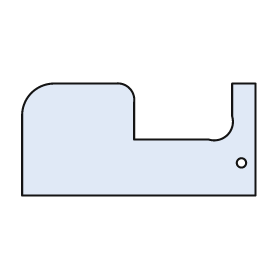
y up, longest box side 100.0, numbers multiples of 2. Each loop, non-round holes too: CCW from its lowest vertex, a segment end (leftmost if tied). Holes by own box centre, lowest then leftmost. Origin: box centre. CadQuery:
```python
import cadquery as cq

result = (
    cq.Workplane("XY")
    .moveTo(-50.0, -24.0)
    .lineTo(50.0, -24.0)
    .lineTo(50.0, 24.0)
    .lineTo(40.0, 24.0)
    .lineTo(40.0, 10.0)
    .threePointArc((38.0, 2.0), (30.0, 0.0))
    .lineTo(-2.0, 0.0)
    .lineTo(-2.0, 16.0)
    .threePointArc((-4.0, 22.0), (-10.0, 24.0))
    .lineTo(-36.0, 24.0)
    .threePointArc((-46.0, 20.0), (-50.0, 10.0))
    .close()
    .moveTo(44.0, -10.0)
    .circle(2.0)
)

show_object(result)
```